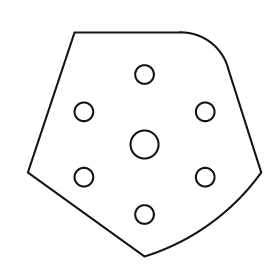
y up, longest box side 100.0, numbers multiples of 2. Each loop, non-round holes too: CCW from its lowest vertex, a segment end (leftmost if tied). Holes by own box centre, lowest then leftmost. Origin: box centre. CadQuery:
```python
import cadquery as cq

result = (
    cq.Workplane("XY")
    .moveTo(0.0, -48.0)
    .threePointArc((28.0, -34.0), (50.0, -12.0))
    .lineTo(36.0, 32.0)
    .threePointArc((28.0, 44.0), (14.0, 48.0))
    .lineTo(-30.0, 48.0)
    .lineTo(-50.0, -12.0)
    .close()
    .moveTo(0.0, -30.0)
    .circle(4.0)
    .moveTo(-26.0, -14.0)
    .circle(4.0)
    .moveTo(26.0, -14.0)
    .circle(4.0)
    .moveTo(0.0, 0.0)
    .circle(6.0)
    .moveTo(-26.0, 14.0)
    .circle(4.0)
    .moveTo(26.0, 14.0)
    .circle(4.0)
    .moveTo(0.0, 30.0)
    .circle(4.0)
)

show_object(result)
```